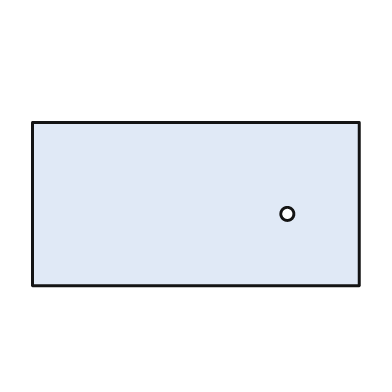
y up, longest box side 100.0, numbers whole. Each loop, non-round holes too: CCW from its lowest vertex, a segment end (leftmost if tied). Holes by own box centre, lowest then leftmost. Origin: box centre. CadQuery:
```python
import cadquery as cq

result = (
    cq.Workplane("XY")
    .moveTo(-50.0, -25.0)
    .lineTo(50.0, -25.0)
    .lineTo(50.0, 25.0)
    .lineTo(-50.0, 25.0)
    .close()
    .moveTo(28.0, -3.0)
    .circle(2.0)
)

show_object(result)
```